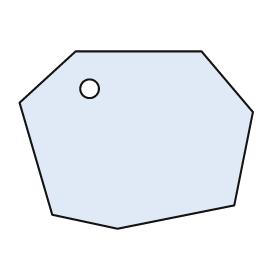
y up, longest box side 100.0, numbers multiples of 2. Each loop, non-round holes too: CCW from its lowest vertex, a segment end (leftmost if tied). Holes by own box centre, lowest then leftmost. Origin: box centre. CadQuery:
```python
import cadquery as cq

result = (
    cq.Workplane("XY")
    .moveTo(-8.0, -38.0)
    .lineTo(42.0, -28.0)
    .lineTo(50.0, 12.0)
    .lineTo(28.0, 38.0)
    .lineTo(-26.0, 38.0)
    .lineTo(-50.0, 16.0)
    .lineTo(-36.0, -32.0)
    .close()
    .moveTo(-20.0, 22.0)
    .circle(4.0)
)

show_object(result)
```